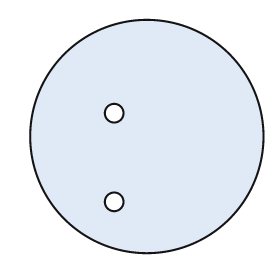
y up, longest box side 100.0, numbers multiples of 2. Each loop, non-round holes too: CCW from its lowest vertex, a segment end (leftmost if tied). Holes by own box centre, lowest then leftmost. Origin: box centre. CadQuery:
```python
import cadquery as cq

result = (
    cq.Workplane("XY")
    .moveTo(0.0, 0.0)
    .circle(50.0)
    .moveTo(-14.0, -28.0)
    .circle(4.0)
    .moveTo(-14.0, 10.0)
    .circle(4.0)
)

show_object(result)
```